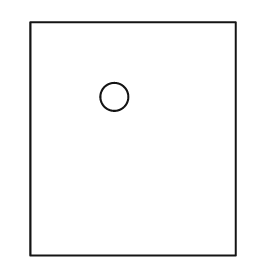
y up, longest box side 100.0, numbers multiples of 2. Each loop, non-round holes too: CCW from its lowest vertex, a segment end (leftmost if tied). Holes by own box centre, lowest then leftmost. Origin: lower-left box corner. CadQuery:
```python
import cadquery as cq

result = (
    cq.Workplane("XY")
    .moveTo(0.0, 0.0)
    .lineTo(88.0, 0.0)
    .lineTo(88.0, 100.0)
    .lineTo(0.0, 100.0)
    .close()
    .moveTo(36.0, 68.0)
    .circle(6.0)
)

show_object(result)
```